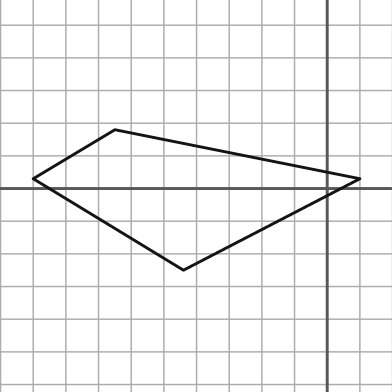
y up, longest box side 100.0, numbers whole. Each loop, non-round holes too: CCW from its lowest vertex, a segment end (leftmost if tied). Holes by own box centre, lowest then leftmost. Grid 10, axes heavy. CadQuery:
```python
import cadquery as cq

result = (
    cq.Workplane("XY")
    .moveTo(-44.0, -25.0)
    .lineTo(10.0, 3.0)
    .lineTo(-65.0, 18.0)
    .lineTo(-90.0, 3.0)
    .close()
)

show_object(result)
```